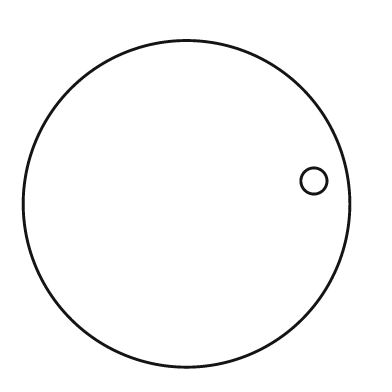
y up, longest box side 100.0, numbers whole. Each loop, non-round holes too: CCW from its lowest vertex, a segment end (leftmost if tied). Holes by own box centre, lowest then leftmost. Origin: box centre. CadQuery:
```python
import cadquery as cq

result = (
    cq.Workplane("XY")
    .moveTo(0.0, 0.0)
    .circle(50.0)
    .moveTo(39.0, 7.0)
    .circle(4.0)
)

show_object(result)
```